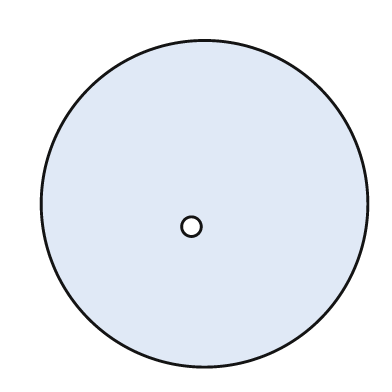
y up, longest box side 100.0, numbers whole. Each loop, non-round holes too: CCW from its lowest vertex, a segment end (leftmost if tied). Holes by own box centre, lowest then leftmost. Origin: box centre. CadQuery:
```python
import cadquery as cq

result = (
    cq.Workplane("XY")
    .moveTo(0.0, 0.0)
    .circle(50.0)
    .moveTo(-4.0, -7.0)
    .circle(3.0)
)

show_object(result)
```